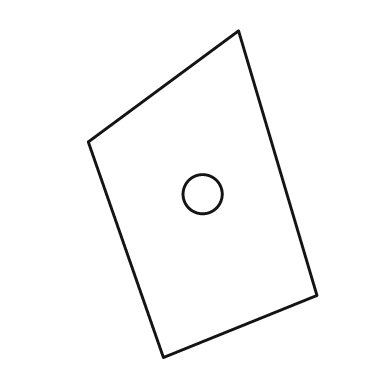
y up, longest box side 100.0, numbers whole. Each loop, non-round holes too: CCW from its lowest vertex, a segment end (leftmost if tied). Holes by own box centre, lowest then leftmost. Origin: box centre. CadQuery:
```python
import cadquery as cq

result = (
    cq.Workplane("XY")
    .moveTo(-12.0, -50.0)
    .lineTo(35.0, -31.0)
    .lineTo(11.0, 50.0)
    .lineTo(-35.0, 16.0)
    .close()
    .moveTo(0.0, 0.0)
    .circle(6.0)
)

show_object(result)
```